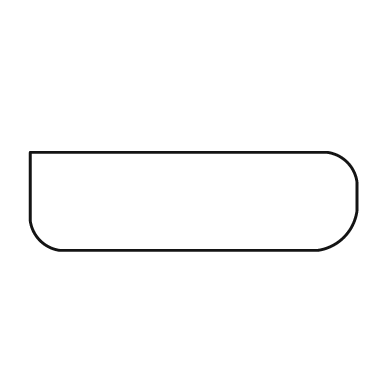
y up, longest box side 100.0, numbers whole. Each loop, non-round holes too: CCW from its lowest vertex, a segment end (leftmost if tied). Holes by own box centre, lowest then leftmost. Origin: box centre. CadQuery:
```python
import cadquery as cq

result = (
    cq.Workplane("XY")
    .moveTo(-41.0, -15.0)
    .lineTo(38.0, -15.0)
    .threePointArc((46.0, -11.0), (50.0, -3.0))
    .lineTo(50.0, 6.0)
    .threePointArc((47.0, 12.0), (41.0, 15.0))
    .lineTo(-50.0, 15.0)
    .lineTo(-50.0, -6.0)
    .threePointArc((-47.0, -12.0), (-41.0, -15.0))
    .close()
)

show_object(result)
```